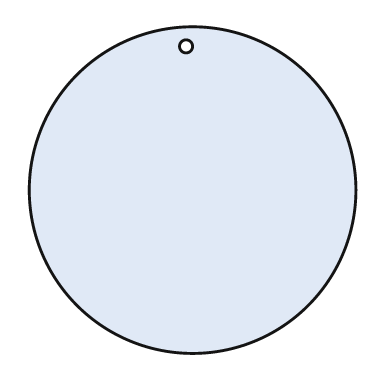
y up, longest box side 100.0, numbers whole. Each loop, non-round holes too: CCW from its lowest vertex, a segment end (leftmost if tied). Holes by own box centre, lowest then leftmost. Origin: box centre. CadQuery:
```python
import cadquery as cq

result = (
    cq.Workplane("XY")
    .moveTo(0.0, 0.0)
    .circle(50.0)
    .moveTo(-2.0, 44.0)
    .circle(2.0)
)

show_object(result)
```